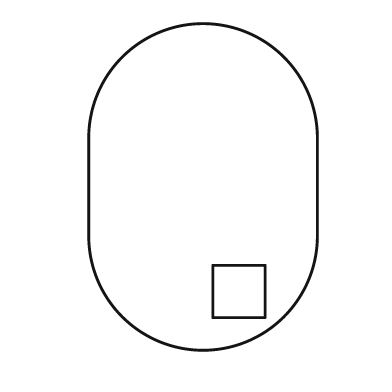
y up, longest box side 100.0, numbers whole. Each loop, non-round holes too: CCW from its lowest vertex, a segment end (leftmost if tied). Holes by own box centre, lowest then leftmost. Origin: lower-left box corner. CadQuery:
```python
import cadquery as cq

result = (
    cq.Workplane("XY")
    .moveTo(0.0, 35.0)
    .threePointArc((35.0, 0.0), (70.0, 35.0))
    .lineTo(70.0, 65.0)
    .threePointArc((35.0, 100.0), (0.0, 65.0))
    .close()
    .moveTo(38.0, 10.0)
    .lineTo(54.0, 10.0)
    .lineTo(54.0, 26.0)
    .lineTo(38.0, 26.0)
    .close()
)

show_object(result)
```